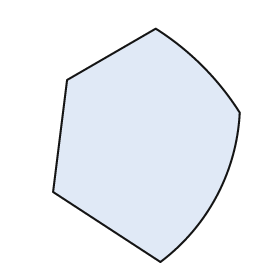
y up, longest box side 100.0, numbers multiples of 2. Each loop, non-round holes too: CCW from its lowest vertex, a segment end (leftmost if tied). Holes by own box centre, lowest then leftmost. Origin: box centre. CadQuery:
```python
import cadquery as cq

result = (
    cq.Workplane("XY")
    .moveTo(6.0, -50.0)
    .threePointArc((30.0, -22.0), (40.0, 14.0))
    .threePointArc((24.0, 34.0), (4.0, 50.0))
    .lineTo(-34.0, 28.0)
    .lineTo(-40.0, -20.0)
    .close()
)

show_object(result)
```